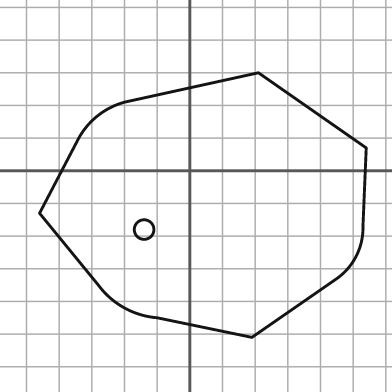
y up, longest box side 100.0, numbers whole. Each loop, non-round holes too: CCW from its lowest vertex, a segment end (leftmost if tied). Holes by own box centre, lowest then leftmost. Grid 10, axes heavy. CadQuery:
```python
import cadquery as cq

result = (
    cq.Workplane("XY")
    .moveTo(19.0, -51.0)
    .lineTo(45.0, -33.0)
    .threePointArc((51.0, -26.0), (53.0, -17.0))
    .lineTo(54.0, 7.0)
    .lineTo(21.0, 30.0)
    .lineTo(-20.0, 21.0)
    .threePointArc((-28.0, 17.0), (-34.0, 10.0))
    .lineTo(-46.0, -13.0)
    .lineTo(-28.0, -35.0)
    .threePointArc((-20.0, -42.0), (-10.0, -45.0))
    .close()
    .moveTo(-14.0, -18.0)
    .circle(3.0)
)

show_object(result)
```